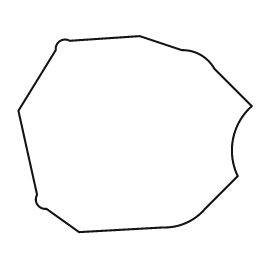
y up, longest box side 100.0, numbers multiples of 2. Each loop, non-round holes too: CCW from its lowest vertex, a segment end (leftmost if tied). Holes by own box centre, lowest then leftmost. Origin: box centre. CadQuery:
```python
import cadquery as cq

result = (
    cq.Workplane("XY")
    .moveTo(-24.0, -42.0)
    .lineTo(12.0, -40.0)
    .threePointArc((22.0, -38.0), (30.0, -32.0))
    .lineTo(44.0, -18.0)
    .threePointArc((42.0, -2.0), (50.0, 12.0))
    .lineTo(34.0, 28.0)
    .threePointArc((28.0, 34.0), (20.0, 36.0))
    .lineTo(2.0, 42.0)
    .lineTo(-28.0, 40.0)
    .threePointArc((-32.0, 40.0), (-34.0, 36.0))
    .lineTo(-50.0, 10.0)
    .lineTo(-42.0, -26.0)
    .threePointArc((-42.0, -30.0), (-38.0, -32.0))
    .close()
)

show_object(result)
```